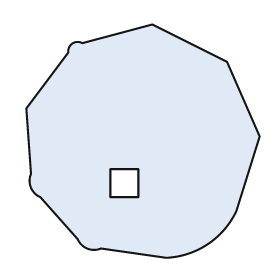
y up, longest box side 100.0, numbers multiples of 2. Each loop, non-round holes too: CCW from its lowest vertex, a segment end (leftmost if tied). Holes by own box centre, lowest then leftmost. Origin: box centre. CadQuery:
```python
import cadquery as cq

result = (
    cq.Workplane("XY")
    .moveTo(10.0, -50.0)
    .threePointArc((28.0, -44.0), (40.0, -30.0))
    .lineTo(50.0, 2.0)
    .lineTo(36.0, 34.0)
    .lineTo(4.0, 50.0)
    .lineTo(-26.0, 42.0)
    .threePointArc((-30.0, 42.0), (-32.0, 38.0))
    .lineTo(-50.0, 14.0)
    .lineTo(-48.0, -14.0)
    .threePointArc((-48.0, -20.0), (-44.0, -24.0))
    .lineTo(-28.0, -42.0)
    .threePointArc((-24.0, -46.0), (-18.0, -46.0))
    .close()
    .moveTo(-14.0, -24.0)
    .lineTo(-2.0, -24.0)
    .lineTo(-2.0, -12.0)
    .lineTo(-14.0, -12.0)
    .close()
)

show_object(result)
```